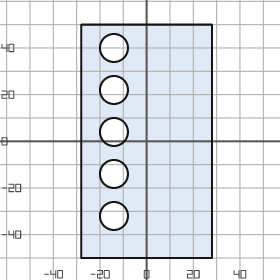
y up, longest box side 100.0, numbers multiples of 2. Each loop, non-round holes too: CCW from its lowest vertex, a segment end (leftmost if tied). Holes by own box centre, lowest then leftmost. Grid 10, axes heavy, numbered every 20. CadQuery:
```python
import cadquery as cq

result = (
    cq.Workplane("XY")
    .moveTo(-28.0, -50.0)
    .lineTo(28.0, -50.0)
    .lineTo(28.0, 50.0)
    .lineTo(-28.0, 50.0)
    .close()
    .moveTo(-14.0, -32.0)
    .circle(6.0)
    .moveTo(-14.0, -14.0)
    .circle(6.0)
    .moveTo(-14.0, 4.0)
    .circle(6.0)
    .moveTo(-14.0, 22.0)
    .circle(6.0)
    .moveTo(-14.0, 40.0)
    .circle(6.0)
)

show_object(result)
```